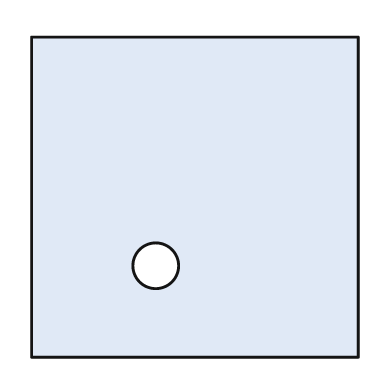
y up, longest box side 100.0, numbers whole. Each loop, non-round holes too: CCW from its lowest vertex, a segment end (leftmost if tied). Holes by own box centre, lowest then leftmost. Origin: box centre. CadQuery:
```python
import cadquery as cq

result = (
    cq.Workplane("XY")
    .moveTo(-50.0, -49.0)
    .lineTo(50.0, -49.0)
    .lineTo(50.0, 49.0)
    .lineTo(-50.0, 49.0)
    .close()
    .moveTo(-12.0, -21.0)
    .circle(7.0)
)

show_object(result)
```